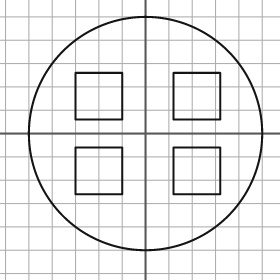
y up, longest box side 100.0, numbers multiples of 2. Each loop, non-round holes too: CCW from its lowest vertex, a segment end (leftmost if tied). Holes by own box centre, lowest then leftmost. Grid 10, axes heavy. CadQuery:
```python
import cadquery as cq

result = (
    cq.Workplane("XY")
    .moveTo(0.0, 0.0)
    .circle(50.0)
    .moveTo(-30.0, -26.0)
    .lineTo(-10.0, -26.0)
    .lineTo(-10.0, -6.0)
    .lineTo(-30.0, -6.0)
    .close()
    .moveTo(12.0, -26.0)
    .lineTo(32.0, -26.0)
    .lineTo(32.0, -6.0)
    .lineTo(12.0, -6.0)
    .close()
    .moveTo(-30.0, 6.0)
    .lineTo(-10.0, 6.0)
    .lineTo(-10.0, 26.0)
    .lineTo(-30.0, 26.0)
    .close()
    .moveTo(12.0, 6.0)
    .lineTo(32.0, 6.0)
    .lineTo(32.0, 26.0)
    .lineTo(12.0, 26.0)
    .close()
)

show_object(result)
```